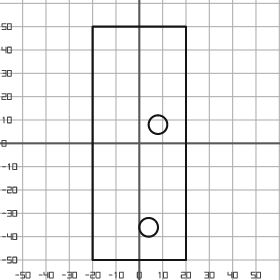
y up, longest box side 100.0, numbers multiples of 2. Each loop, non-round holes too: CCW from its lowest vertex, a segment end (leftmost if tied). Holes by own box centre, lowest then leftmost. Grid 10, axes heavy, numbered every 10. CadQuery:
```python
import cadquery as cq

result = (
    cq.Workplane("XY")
    .moveTo(-20.0, -50.0)
    .lineTo(20.0, -50.0)
    .lineTo(20.0, 50.0)
    .lineTo(-20.0, 50.0)
    .close()
    .moveTo(4.0, -36.0)
    .circle(4.0)
    .moveTo(8.0, 8.0)
    .circle(4.0)
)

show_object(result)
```